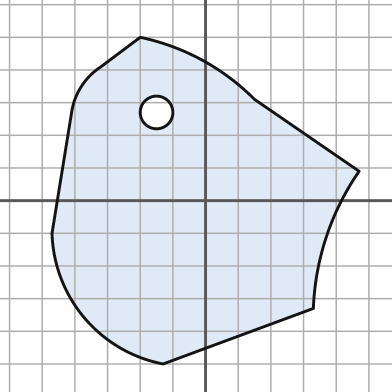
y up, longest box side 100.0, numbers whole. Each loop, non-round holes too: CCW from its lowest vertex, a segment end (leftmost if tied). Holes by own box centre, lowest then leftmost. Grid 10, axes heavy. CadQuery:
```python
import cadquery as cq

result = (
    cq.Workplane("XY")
    .moveTo(-13.0, -50.0)
    .lineTo(33.0, -33.0)
    .threePointArc((37.0, -11.0), (47.0, 9.0))
    .lineTo(15.0, 31.0)
    .threePointArc((-1.0, 43.0), (-20.0, 50.0))
    .lineTo(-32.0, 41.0)
    .threePointArc((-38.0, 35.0), (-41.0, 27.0))
    .lineTo(-47.0, -10.0)
    .threePointArc((-37.0, -36.0), (-13.0, -50.0))
    .close()
    .moveTo(-15.0, 27.0)
    .circle(5.0)
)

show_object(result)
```